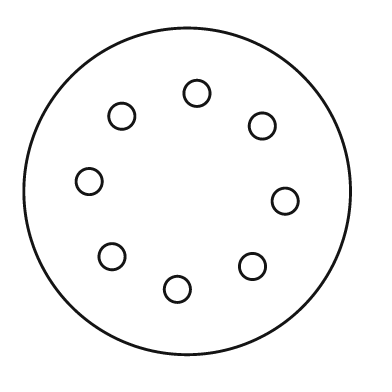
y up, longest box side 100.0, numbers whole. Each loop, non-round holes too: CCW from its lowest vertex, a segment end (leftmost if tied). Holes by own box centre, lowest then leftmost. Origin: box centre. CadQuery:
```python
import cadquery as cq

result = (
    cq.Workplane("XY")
    .moveTo(0.0, 0.0)
    .circle(50.0)
    .moveTo(-3.0, -30.0)
    .circle(4.0)
    .moveTo(20.0, -23.0)
    .circle(4.0)
    .moveTo(-23.0, -20.0)
    .circle(4.0)
    .moveTo(30.0, -3.0)
    .circle(4.0)
    .moveTo(-30.0, 3.0)
    .circle(4.0)
    .moveTo(23.0, 20.0)
    .circle(4.0)
    .moveTo(-20.0, 23.0)
    .circle(4.0)
    .moveTo(3.0, 30.0)
    .circle(4.0)
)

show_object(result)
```